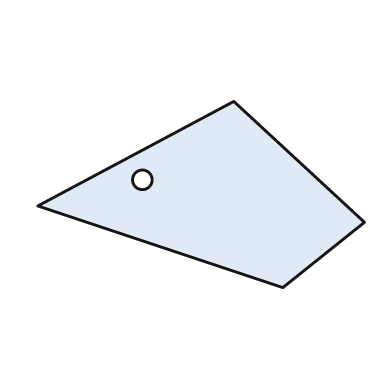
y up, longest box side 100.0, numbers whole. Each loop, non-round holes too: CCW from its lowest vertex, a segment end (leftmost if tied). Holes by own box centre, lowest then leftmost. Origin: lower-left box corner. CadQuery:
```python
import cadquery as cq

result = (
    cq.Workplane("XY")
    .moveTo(75.0, 0.0)
    .lineTo(100.0, 20.0)
    .lineTo(60.0, 57.0)
    .lineTo(0.0, 25.0)
    .close()
    .moveTo(32.0, 33.0)
    .circle(3.0)
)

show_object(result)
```